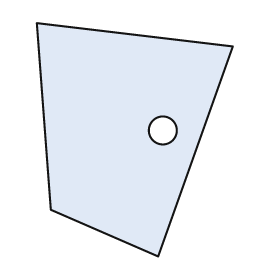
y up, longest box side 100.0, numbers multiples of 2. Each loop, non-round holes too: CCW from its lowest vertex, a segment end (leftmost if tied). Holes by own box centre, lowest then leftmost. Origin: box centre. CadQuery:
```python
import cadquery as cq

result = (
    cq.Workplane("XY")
    .moveTo(10.0, -50.0)
    .lineTo(42.0, 40.0)
    .lineTo(-42.0, 50.0)
    .lineTo(-36.0, -30.0)
    .close()
    .moveTo(12.0, 4.0)
    .circle(6.0)
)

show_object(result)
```